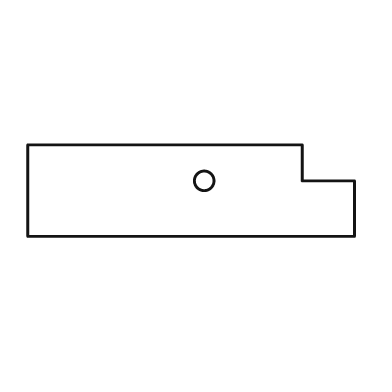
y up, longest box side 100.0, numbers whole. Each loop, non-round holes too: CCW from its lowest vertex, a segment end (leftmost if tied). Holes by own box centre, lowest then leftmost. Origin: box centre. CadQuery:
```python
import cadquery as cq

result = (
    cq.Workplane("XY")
    .moveTo(-50.0, -14.0)
    .lineTo(50.0, -14.0)
    .lineTo(50.0, 3.0)
    .lineTo(34.0, 3.0)
    .lineTo(34.0, 14.0)
    .lineTo(-50.0, 14.0)
    .close()
    .moveTo(4.0, 3.0)
    .circle(3.0)
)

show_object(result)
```